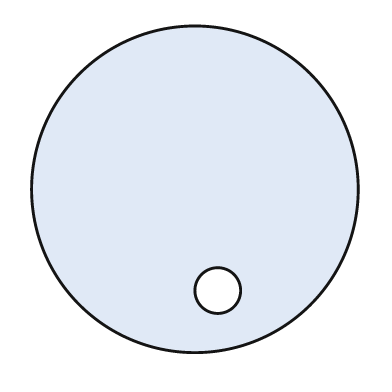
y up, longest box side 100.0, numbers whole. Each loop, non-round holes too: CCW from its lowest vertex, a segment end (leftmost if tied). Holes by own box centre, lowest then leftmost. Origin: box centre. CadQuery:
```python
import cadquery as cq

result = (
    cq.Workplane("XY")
    .moveTo(0.0, 0.0)
    .circle(50.0)
    .moveTo(7.0, -31.0)
    .circle(7.0)
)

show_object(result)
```